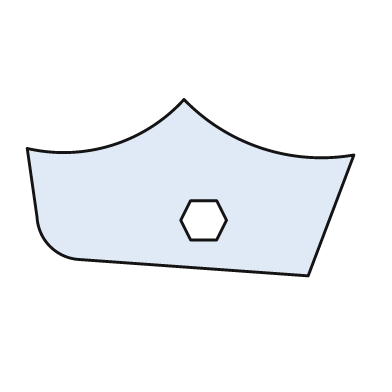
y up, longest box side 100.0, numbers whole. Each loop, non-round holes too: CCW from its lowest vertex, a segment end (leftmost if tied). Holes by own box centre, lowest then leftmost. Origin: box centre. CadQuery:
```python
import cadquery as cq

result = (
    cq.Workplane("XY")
    .moveTo(36.0, -27.0)
    .lineTo(50.0, 10.0)
    .threePointArc((22.0, 12.0), (-2.0, 27.0))
    .threePointArc((-24.0, 13.0), (-50.0, 12.0))
    .lineTo(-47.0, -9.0)
    .threePointArc((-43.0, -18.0), (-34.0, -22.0))
    .close()
    .moveTo(0.0, -16.0)
    .lineTo(8.0, -16.0)
    .lineTo(11.0, -10.0)
    .lineTo(8.0, -4.0)
    .lineTo(0.0, -4.0)
    .lineTo(-3.0, -10.0)
    .close()
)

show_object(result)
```